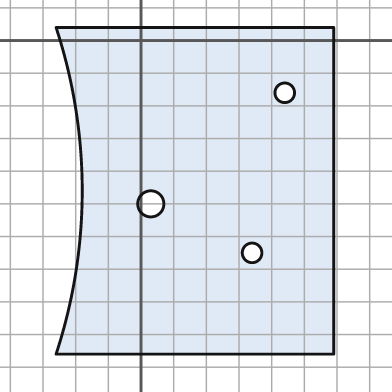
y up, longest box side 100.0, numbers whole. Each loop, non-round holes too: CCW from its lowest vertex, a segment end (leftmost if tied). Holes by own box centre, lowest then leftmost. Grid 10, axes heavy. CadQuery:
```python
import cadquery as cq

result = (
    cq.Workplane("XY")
    .moveTo(-26.0, -96.0)
    .lineTo(59.0, -96.0)
    .lineTo(59.0, 4.0)
    .lineTo(-26.0, 4.0)
    .threePointArc((-18.0, -46.0), (-26.0, -96.0))
    .close()
    .moveTo(34.0, -65.0)
    .circle(3.0)
    .moveTo(3.0, -50.0)
    .circle(4.0)
    .moveTo(44.0, -16.0)
    .circle(3.0)
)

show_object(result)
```